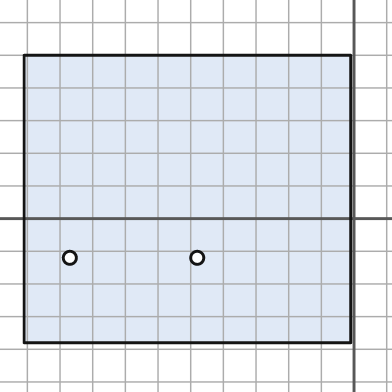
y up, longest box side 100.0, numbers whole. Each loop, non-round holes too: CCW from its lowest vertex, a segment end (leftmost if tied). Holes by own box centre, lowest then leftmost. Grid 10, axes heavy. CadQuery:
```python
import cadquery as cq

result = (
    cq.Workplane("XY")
    .moveTo(-101.0, -38.0)
    .lineTo(-1.0, -38.0)
    .lineTo(-1.0, 50.0)
    .lineTo(-101.0, 50.0)
    .close()
    .moveTo(-87.0, -12.0)
    .circle(2.0)
    .moveTo(-48.0, -12.0)
    .circle(2.0)
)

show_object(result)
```